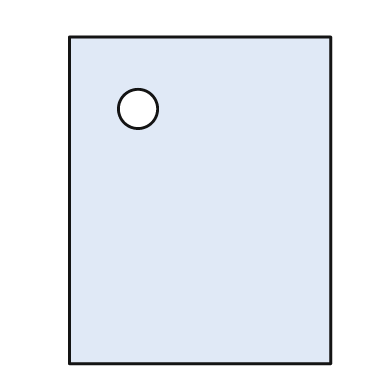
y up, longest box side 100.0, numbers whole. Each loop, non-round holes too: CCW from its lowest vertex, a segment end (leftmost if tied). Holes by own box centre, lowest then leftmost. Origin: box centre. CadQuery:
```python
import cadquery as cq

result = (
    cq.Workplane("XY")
    .moveTo(-40.0, -50.0)
    .lineTo(40.0, -50.0)
    .lineTo(40.0, 50.0)
    .lineTo(-40.0, 50.0)
    .close()
    .moveTo(-19.0, 28.0)
    .circle(6.0)
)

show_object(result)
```